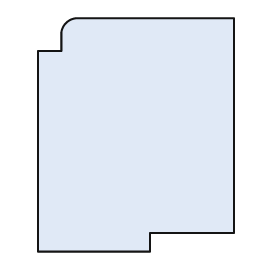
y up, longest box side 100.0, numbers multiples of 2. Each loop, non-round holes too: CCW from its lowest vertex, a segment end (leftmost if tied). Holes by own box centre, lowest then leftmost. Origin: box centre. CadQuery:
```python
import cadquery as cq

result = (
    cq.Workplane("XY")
    .moveTo(-42.0, -50.0)
    .lineTo(6.0, -50.0)
    .lineTo(6.0, -42.0)
    .lineTo(42.0, -42.0)
    .lineTo(42.0, 50.0)
    .lineTo(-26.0, 50.0)
    .threePointArc((-30.0, 48.0), (-32.0, 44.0))
    .lineTo(-32.0, 36.0)
    .lineTo(-42.0, 36.0)
    .close()
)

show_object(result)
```